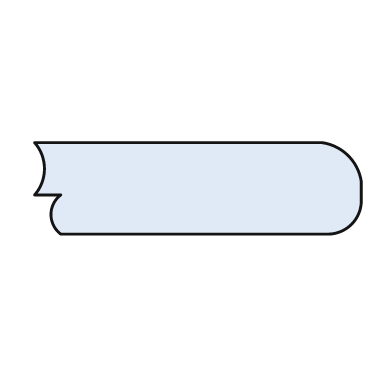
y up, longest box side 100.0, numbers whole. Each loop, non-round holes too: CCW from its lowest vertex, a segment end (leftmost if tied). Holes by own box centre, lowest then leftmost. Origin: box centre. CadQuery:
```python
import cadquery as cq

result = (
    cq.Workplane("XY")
    .moveTo(-42.0, -14.0)
    .lineTo(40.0, -14.0)
    .threePointArc((47.0, -11.0), (50.0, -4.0))
    .lineTo(50.0, 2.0)
    .threePointArc((46.0, 10.0), (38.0, 14.0))
    .lineTo(-50.0, 14.0)
    .threePointArc((-47.0, 6.0), (-50.0, -2.0))
    .lineTo(-42.0, -2.0)
    .threePointArc((-45.0, -8.0), (-42.0, -14.0))
    .close()
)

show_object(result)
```